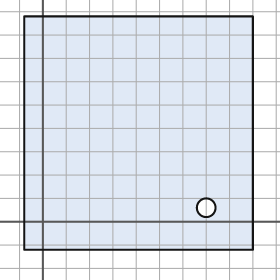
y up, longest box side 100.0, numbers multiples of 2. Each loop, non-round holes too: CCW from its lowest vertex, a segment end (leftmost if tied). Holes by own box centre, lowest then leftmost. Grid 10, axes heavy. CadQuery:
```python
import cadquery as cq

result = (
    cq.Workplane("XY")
    .moveTo(-8.0, -12.0)
    .lineTo(90.0, -12.0)
    .lineTo(90.0, 88.0)
    .lineTo(-8.0, 88.0)
    .close()
    .moveTo(70.0, 6.0)
    .circle(4.0)
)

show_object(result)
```